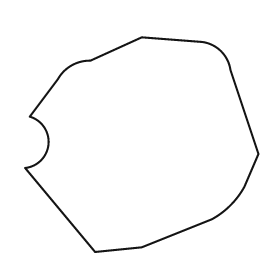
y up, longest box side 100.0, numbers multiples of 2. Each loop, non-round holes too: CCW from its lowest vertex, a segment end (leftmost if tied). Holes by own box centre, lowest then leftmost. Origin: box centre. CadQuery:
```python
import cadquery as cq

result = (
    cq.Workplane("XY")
    .moveTo(-20.0, -46.0)
    .lineTo(0.0, -44.0)
    .lineTo(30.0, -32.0)
    .threePointArc((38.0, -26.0), (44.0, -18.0))
    .lineTo(50.0, -4.0)
    .lineTo(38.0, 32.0)
    .threePointArc((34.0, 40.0), (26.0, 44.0))
    .lineTo(0.0, 46.0)
    .lineTo(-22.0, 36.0)
    .threePointArc((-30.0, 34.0), (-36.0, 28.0))
    .lineTo(-48.0, 12.0)
    .threePointArc((-40.0, 0.0), (-50.0, -10.0))
    .close()
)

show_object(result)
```